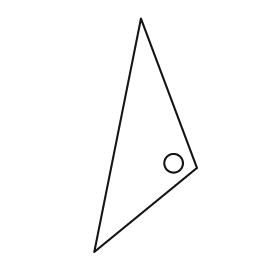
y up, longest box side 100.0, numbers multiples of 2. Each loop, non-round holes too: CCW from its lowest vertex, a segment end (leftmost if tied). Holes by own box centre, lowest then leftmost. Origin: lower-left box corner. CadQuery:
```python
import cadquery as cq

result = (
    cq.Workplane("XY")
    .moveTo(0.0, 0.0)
    .lineTo(44.0, 36.0)
    .lineTo(20.0, 100.0)
    .close()
    .moveTo(34.0, 38.0)
    .circle(4.0)
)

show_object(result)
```